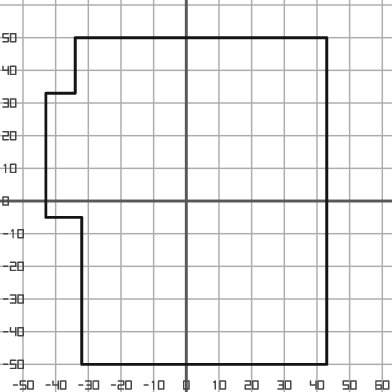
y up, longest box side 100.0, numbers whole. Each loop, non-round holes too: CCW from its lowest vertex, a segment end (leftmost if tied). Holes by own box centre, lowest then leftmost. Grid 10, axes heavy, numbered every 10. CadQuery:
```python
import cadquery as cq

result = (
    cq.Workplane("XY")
    .moveTo(-32.0, -50.0)
    .lineTo(43.0, -50.0)
    .lineTo(43.0, 50.0)
    .lineTo(-34.0, 50.0)
    .lineTo(-34.0, 33.0)
    .lineTo(-43.0, 33.0)
    .lineTo(-43.0, -5.0)
    .lineTo(-32.0, -5.0)
    .close()
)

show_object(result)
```